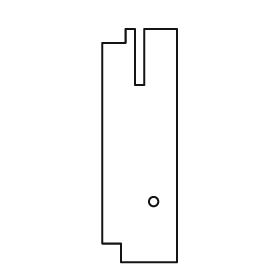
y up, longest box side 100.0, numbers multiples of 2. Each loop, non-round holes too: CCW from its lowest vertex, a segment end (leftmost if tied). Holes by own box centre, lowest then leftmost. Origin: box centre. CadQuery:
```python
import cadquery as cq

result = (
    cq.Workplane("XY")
    .moveTo(-8.0, -50.0)
    .lineTo(16.0, -50.0)
    .lineTo(16.0, 50.0)
    .lineTo(2.0, 50.0)
    .lineTo(2.0, 26.0)
    .lineTo(-2.0, 26.0)
    .lineTo(-2.0, 50.0)
    .lineTo(-6.0, 50.0)
    .lineTo(-6.0, 44.0)
    .lineTo(-16.0, 44.0)
    .lineTo(-16.0, -42.0)
    .lineTo(-8.0, -42.0)
    .close()
    .moveTo(6.0, -24.0)
    .circle(2.0)
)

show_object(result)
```